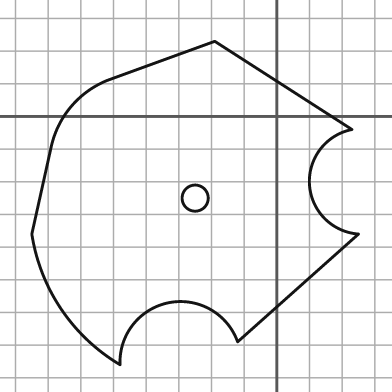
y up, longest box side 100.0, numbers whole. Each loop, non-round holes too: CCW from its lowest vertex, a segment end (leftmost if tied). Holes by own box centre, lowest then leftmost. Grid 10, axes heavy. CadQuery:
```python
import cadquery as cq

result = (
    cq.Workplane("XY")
    .moveTo(-48.0, -76.0)
    .threePointArc((-33.0, -57.0), (-12.0, -69.0))
    .lineTo(25.0, -36.0)
    .threePointArc((10.0, -21.0), (23.0, -4.0))
    .lineTo(-19.0, 23.0)
    .lineTo(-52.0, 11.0)
    .threePointArc((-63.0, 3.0), (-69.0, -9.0))
    .lineTo(-75.0, -36.0)
    .threePointArc((-66.0, -59.0), (-48.0, -76.0))
    .close()
    .moveTo(-25.0, -25.0)
    .circle(4.0)
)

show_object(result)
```